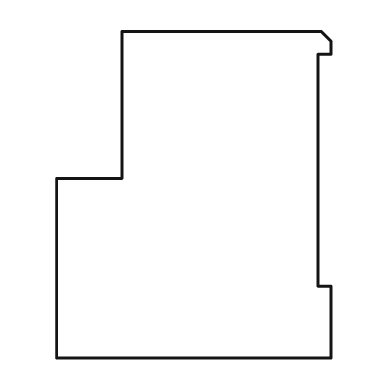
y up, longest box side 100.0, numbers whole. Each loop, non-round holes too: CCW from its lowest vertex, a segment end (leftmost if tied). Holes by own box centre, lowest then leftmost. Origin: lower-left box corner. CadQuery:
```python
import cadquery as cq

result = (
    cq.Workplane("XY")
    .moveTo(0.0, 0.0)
    .lineTo(84.0, 0.0)
    .lineTo(84.0, 22.0)
    .lineTo(80.0, 22.0)
    .lineTo(80.0, 93.0)
    .lineTo(84.0, 93.0)
    .lineTo(84.0, 97.0)
    .lineTo(81.0, 100.0)
    .lineTo(20.0, 100.0)
    .lineTo(20.0, 55.0)
    .lineTo(0.0, 55.0)
    .close()
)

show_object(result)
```